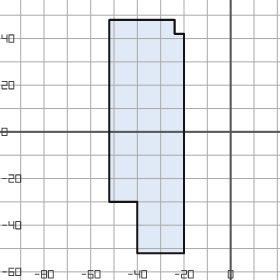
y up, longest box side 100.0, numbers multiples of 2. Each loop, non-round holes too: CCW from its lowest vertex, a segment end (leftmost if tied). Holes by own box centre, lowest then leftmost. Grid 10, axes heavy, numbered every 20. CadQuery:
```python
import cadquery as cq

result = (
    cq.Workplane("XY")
    .moveTo(-40.0, -52.0)
    .lineTo(-20.0, -52.0)
    .lineTo(-20.0, 42.0)
    .lineTo(-24.0, 42.0)
    .lineTo(-24.0, 48.0)
    .lineTo(-52.0, 48.0)
    .lineTo(-52.0, -30.0)
    .lineTo(-40.0, -30.0)
    .close()
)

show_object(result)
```